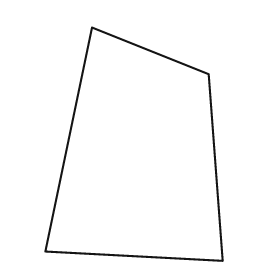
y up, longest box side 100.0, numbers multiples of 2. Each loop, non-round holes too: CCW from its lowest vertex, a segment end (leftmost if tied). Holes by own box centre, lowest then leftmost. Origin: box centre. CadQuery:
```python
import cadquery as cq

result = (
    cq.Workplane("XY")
    .moveTo(38.0, -50.0)
    .lineTo(32.0, 30.0)
    .lineTo(-18.0, 50.0)
    .lineTo(-38.0, -46.0)
    .close()
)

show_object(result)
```